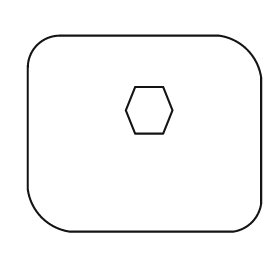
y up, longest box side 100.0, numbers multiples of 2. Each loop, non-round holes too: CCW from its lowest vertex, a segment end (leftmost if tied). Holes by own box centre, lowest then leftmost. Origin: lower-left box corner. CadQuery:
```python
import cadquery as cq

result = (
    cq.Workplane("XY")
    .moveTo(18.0, 0.0)
    .lineTo(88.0, 0.0)
    .threePointArc((96.0, 4.0), (100.0, 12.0))
    .lineTo(100.0, 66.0)
    .threePointArc((94.0, 78.0), (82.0, 84.0))
    .lineTo(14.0, 84.0)
    .threePointArc((4.0, 80.0), (0.0, 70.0))
    .lineTo(0.0, 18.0)
    .threePointArc((6.0, 6.0), (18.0, 0.0))
    .close()
    .moveTo(46.0, 42.0)
    .lineTo(58.0, 42.0)
    .lineTo(62.0, 52.0)
    .lineTo(58.0, 62.0)
    .lineTo(46.0, 62.0)
    .lineTo(42.0, 52.0)
    .close()
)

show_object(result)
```